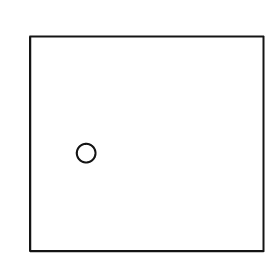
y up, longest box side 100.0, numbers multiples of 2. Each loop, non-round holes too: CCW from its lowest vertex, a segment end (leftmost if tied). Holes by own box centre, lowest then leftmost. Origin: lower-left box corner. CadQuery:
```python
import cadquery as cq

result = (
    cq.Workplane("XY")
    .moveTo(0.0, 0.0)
    .lineTo(100.0, 0.0)
    .lineTo(100.0, 92.0)
    .lineTo(0.0, 92.0)
    .close()
    .moveTo(24.0, 42.0)
    .circle(4.0)
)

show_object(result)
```